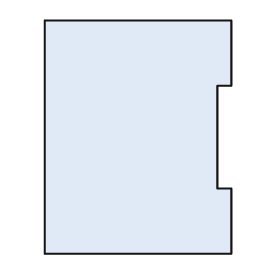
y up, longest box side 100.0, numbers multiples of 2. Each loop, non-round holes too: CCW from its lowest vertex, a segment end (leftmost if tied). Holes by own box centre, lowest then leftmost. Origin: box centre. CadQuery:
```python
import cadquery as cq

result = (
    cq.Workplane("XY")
    .moveTo(-40.0, -50.0)
    .lineTo(40.0, -50.0)
    .lineTo(40.0, -22.0)
    .lineTo(34.0, -22.0)
    .lineTo(34.0, 22.0)
    .lineTo(40.0, 22.0)
    .lineTo(40.0, 50.0)
    .lineTo(-40.0, 50.0)
    .close()
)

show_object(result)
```